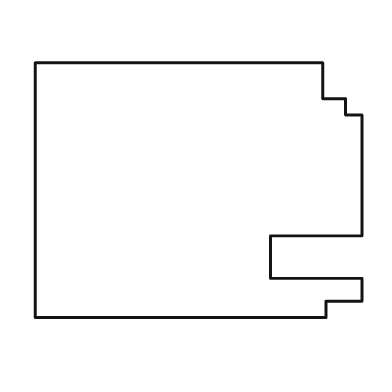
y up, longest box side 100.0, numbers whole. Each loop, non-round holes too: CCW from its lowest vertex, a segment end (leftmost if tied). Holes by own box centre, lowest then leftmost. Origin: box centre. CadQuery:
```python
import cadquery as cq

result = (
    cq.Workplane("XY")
    .moveTo(-50.0, -39.0)
    .lineTo(39.0, -39.0)
    .lineTo(39.0, -34.0)
    .lineTo(50.0, -34.0)
    .lineTo(50.0, -27.0)
    .lineTo(22.0, -27.0)
    .lineTo(22.0, -14.0)
    .lineTo(50.0, -14.0)
    .lineTo(50.0, 23.0)
    .lineTo(45.0, 23.0)
    .lineTo(45.0, 28.0)
    .lineTo(38.0, 28.0)
    .lineTo(38.0, 39.0)
    .lineTo(-50.0, 39.0)
    .close()
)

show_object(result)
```